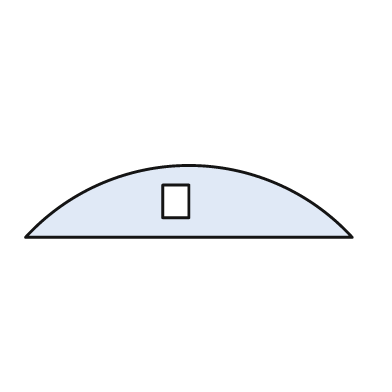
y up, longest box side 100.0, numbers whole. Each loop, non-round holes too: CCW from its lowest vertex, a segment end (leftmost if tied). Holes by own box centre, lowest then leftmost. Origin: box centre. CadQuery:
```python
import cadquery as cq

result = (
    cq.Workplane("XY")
    .moveTo(-50.0, -11.0)
    .lineTo(50.0, -11.0)
    .threePointArc((0.0, 11.0), (-50.0, -11.0))
    .close()
    .moveTo(-8.0, -5.0)
    .lineTo(0.0, -5.0)
    .lineTo(0.0, 5.0)
    .lineTo(-8.0, 5.0)
    .close()
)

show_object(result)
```